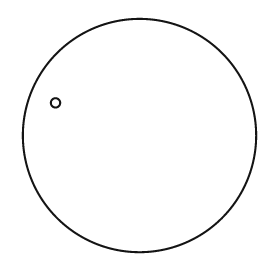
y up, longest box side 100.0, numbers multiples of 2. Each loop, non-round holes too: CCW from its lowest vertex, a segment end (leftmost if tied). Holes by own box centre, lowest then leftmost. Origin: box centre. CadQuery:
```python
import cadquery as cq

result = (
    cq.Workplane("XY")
    .moveTo(0.0, 0.0)
    .circle(50.0)
    .moveTo(-36.0, 14.0)
    .circle(2.0)
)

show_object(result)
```